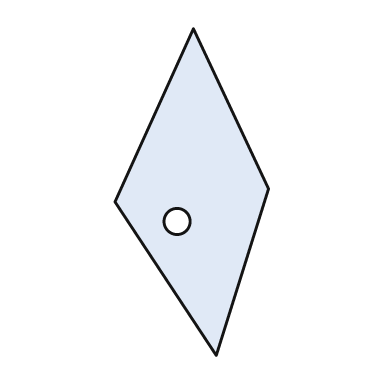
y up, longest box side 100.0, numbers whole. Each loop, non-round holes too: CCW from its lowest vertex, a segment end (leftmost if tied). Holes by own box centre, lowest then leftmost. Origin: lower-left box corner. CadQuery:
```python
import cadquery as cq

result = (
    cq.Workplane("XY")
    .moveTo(31.0, 0.0)
    .lineTo(47.0, 51.0)
    .lineTo(24.0, 100.0)
    .lineTo(0.0, 47.0)
    .close()
    .moveTo(19.0, 41.0)
    .circle(4.0)
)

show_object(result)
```